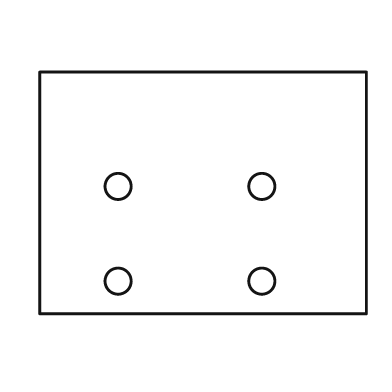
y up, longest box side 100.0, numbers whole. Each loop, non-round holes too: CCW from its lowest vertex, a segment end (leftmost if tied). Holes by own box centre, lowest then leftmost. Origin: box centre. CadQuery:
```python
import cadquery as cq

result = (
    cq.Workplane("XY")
    .moveTo(-50.0, -37.0)
    .lineTo(50.0, -37.0)
    .lineTo(50.0, 37.0)
    .lineTo(-50.0, 37.0)
    .close()
    .moveTo(-26.0, -27.0)
    .circle(4.0)
    .moveTo(18.0, -27.0)
    .circle(4.0)
    .moveTo(-26.0, 2.0)
    .circle(4.0)
    .moveTo(18.0, 2.0)
    .circle(4.0)
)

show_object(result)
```